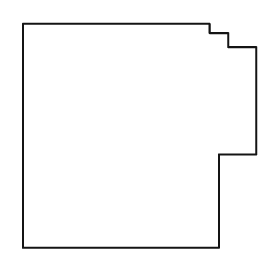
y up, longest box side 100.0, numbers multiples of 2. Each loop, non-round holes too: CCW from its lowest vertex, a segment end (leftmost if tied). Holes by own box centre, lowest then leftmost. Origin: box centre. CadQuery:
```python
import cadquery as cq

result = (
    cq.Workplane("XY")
    .moveTo(-50.0, -48.0)
    .lineTo(34.0, -48.0)
    .lineTo(34.0, -8.0)
    .lineTo(50.0, -8.0)
    .lineTo(50.0, 38.0)
    .lineTo(38.0, 38.0)
    .lineTo(38.0, 44.0)
    .lineTo(30.0, 44.0)
    .lineTo(30.0, 48.0)
    .lineTo(-50.0, 48.0)
    .close()
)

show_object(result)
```